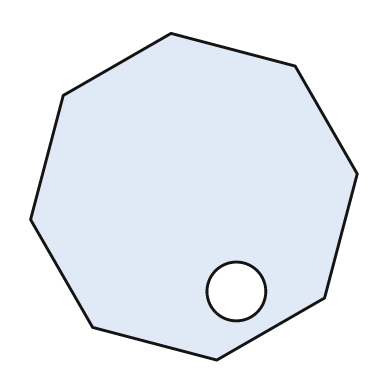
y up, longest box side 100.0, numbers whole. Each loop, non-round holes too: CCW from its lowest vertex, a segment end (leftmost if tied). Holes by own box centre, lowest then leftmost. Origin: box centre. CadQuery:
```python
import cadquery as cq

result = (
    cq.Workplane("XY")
    .moveTo(7.0, -50.0)
    .lineTo(40.0, -31.0)
    .lineTo(50.0, 7.0)
    .lineTo(31.0, 40.0)
    .lineTo(-7.0, 50.0)
    .lineTo(-40.0, 31.0)
    .lineTo(-50.0, -7.0)
    .lineTo(-31.0, -40.0)
    .close()
    .moveTo(13.0, -29.0)
    .circle(9.0)
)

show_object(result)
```